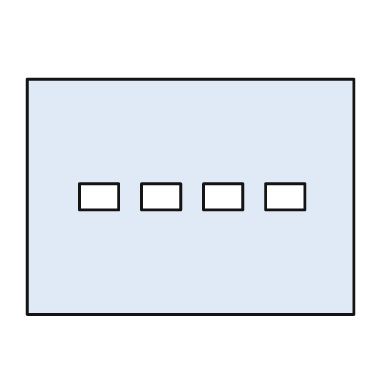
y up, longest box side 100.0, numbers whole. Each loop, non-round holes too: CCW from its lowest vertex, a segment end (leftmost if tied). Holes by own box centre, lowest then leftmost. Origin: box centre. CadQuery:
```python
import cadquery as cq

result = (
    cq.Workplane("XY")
    .moveTo(-50.0, -36.0)
    .lineTo(50.0, -36.0)
    .lineTo(50.0, 36.0)
    .lineTo(-50.0, 36.0)
    .close()
    .moveTo(-34.0, -4.0)
    .lineTo(-22.0, -4.0)
    .lineTo(-22.0, 4.0)
    .lineTo(-34.0, 4.0)
    .close()
    .moveTo(-15.0, -4.0)
    .lineTo(-3.0, -4.0)
    .lineTo(-3.0, 4.0)
    .lineTo(-15.0, 4.0)
    .close()
    .moveTo(4.0, -4.0)
    .lineTo(16.0, -4.0)
    .lineTo(16.0, 4.0)
    .lineTo(4.0, 4.0)
    .close()
    .moveTo(23.0, -4.0)
    .lineTo(35.0, -4.0)
    .lineTo(35.0, 4.0)
    .lineTo(23.0, 4.0)
    .close()
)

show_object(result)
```